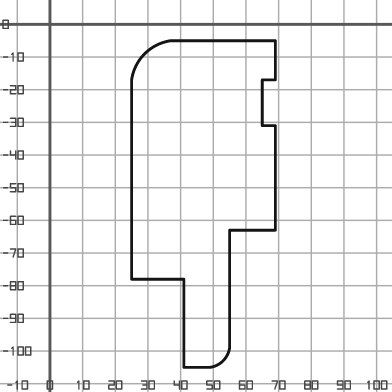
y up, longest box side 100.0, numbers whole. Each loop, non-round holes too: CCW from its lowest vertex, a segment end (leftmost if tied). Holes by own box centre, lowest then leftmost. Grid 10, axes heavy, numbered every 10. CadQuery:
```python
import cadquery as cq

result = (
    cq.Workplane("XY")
    .moveTo(41.0, -105.0)
    .lineTo(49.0, -105.0)
    .threePointArc((53.0, -103.0), (55.0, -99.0))
    .lineTo(55.0, -63.0)
    .lineTo(69.0, -63.0)
    .lineTo(69.0, -31.0)
    .lineTo(65.0, -31.0)
    .lineTo(65.0, -17.0)
    .lineTo(69.0, -17.0)
    .lineTo(69.0, -5.0)
    .lineTo(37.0, -5.0)
    .threePointArc((29.0, -9.0), (25.0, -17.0))
    .lineTo(25.0, -78.0)
    .lineTo(41.0, -78.0)
    .close()
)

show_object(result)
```